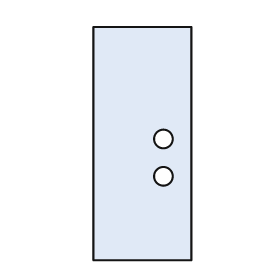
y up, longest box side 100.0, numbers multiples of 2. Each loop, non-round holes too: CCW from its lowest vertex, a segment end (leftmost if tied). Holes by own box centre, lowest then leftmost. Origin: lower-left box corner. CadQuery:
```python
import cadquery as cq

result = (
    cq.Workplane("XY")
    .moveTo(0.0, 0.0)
    .lineTo(42.0, 0.0)
    .lineTo(42.0, 100.0)
    .lineTo(0.0, 100.0)
    .close()
    .moveTo(30.0, 36.0)
    .circle(4.0)
    .moveTo(30.0, 52.0)
    .circle(4.0)
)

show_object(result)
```